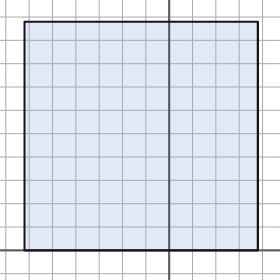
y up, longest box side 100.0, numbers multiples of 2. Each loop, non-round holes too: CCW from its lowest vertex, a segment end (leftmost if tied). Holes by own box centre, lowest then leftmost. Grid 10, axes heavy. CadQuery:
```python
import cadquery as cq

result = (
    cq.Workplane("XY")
    .moveTo(-62.0, 0.0)
    .lineTo(38.0, 0.0)
    .lineTo(38.0, 98.0)
    .lineTo(-62.0, 98.0)
    .close()
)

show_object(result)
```